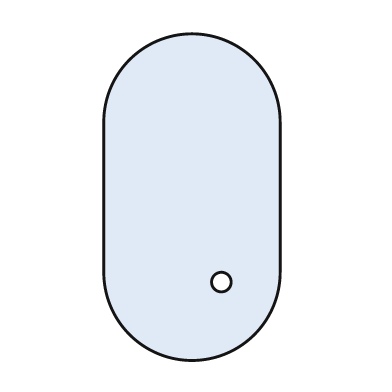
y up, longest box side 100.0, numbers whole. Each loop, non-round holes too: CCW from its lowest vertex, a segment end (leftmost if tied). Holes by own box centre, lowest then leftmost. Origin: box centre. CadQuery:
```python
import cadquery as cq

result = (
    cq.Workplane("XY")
    .moveTo(-27.0, -23.0)
    .threePointArc((0.0, -50.0), (27.0, -23.0))
    .lineTo(27.0, 23.0)
    .threePointArc((0.0, 50.0), (-27.0, 23.0))
    .close()
    .moveTo(9.0, -26.0)
    .circle(3.0)
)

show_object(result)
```